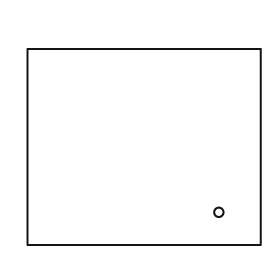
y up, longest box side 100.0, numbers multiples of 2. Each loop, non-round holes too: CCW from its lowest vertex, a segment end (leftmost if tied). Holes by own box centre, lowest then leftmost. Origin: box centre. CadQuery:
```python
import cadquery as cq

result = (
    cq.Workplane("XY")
    .moveTo(-50.0, -42.0)
    .lineTo(50.0, -42.0)
    .lineTo(50.0, 42.0)
    .lineTo(-50.0, 42.0)
    .close()
    .moveTo(32.0, -28.0)
    .circle(2.0)
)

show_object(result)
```